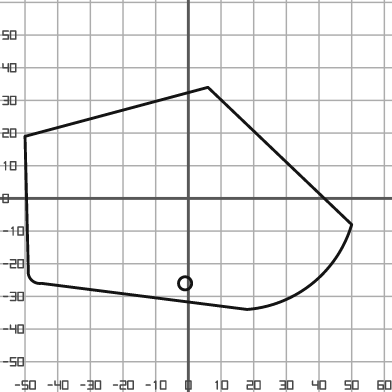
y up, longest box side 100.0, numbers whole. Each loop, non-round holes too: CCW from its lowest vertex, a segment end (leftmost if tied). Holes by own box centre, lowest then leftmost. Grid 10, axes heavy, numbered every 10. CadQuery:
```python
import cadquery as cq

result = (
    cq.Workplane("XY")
    .moveTo(18.0, -34.0)
    .threePointArc((38.0, -26.0), (50.0, -8.0))
    .lineTo(6.0, 34.0)
    .lineTo(-50.0, 19.0)
    .lineTo(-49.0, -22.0)
    .threePointArc((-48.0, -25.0), (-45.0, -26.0))
    .close()
    .moveTo(-1.0, -26.0)
    .circle(2.0)
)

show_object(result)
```